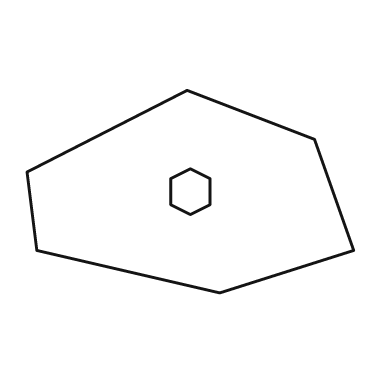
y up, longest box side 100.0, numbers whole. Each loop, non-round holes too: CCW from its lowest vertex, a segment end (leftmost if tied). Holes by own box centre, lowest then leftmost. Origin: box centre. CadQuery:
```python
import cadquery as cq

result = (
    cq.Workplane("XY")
    .moveTo(9.0, -31.0)
    .lineTo(50.0, -18.0)
    .lineTo(38.0, 16.0)
    .lineTo(-1.0, 31.0)
    .lineTo(-50.0, 6.0)
    .lineTo(-47.0, -18.0)
    .close()
    .moveTo(0.0, -7.0)
    .lineTo(6.0, -4.0)
    .lineTo(6.0, 4.0)
    .lineTo(0.0, 7.0)
    .lineTo(-6.0, 4.0)
    .lineTo(-6.0, -4.0)
    .close()
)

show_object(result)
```